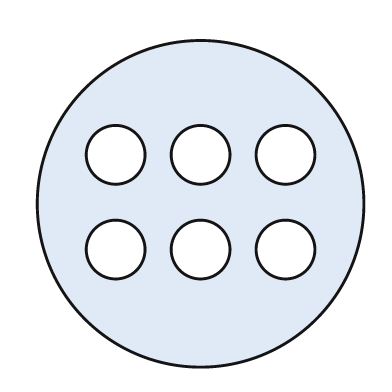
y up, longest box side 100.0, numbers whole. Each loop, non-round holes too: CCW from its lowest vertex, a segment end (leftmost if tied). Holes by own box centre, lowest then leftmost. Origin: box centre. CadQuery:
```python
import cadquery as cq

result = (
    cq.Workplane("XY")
    .moveTo(0.0, 0.0)
    .circle(50.0)
    .moveTo(-26.0, -14.0)
    .circle(9.0)
    .moveTo(0.0, -14.0)
    .circle(9.0)
    .moveTo(26.0, -14.0)
    .circle(9.0)
    .moveTo(-26.0, 15.0)
    .circle(9.0)
    .moveTo(0.0, 15.0)
    .circle(9.0)
    .moveTo(26.0, 15.0)
    .circle(9.0)
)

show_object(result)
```